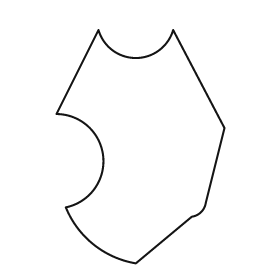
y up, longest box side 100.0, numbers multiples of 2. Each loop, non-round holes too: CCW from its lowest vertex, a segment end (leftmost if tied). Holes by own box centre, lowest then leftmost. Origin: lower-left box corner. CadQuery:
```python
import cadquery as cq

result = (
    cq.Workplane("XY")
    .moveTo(34.0, 0.0)
    .lineTo(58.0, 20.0)
    .threePointArc((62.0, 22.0), (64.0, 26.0))
    .lineTo(72.0, 58.0)
    .lineTo(50.0, 100.0)
    .threePointArc((34.0, 88.0), (18.0, 100.0))
    .lineTo(0.0, 64.0)
    .threePointArc((20.0, 46.0), (4.0, 24.0))
    .threePointArc((16.0, 8.0), (34.0, 0.0))
    .close()
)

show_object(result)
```